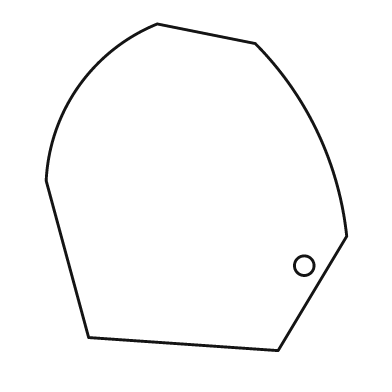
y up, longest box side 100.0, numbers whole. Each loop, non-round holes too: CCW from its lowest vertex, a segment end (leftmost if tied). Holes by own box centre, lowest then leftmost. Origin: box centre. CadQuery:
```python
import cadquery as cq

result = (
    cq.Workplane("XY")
    .moveTo(25.0, -50.0)
    .lineTo(46.0, -15.0)
    .threePointArc((37.0, 17.0), (18.0, 44.0))
    .lineTo(-12.0, 50.0)
    .threePointArc((-36.0, 31.0), (-46.0, 2.0))
    .lineTo(-33.0, -46.0)
    .close()
    .moveTo(33.0, -24.0)
    .circle(3.0)
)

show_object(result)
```